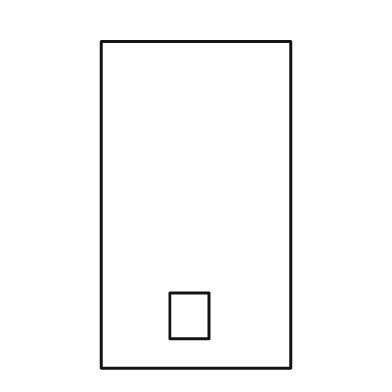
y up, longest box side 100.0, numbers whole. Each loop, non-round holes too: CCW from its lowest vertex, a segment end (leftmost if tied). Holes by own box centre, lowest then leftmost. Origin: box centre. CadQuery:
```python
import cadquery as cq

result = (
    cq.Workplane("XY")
    .moveTo(-29.0, -50.0)
    .lineTo(29.0, -50.0)
    .lineTo(29.0, 50.0)
    .lineTo(-29.0, 50.0)
    .close()
    .moveTo(-8.0, -41.0)
    .lineTo(4.0, -41.0)
    .lineTo(4.0, -27.0)
    .lineTo(-8.0, -27.0)
    .close()
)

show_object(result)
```